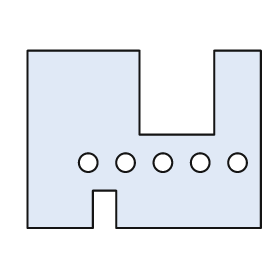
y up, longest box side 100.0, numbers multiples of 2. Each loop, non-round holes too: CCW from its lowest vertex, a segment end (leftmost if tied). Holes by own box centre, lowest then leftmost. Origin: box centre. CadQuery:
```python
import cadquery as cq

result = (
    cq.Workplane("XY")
    .moveTo(-50.0, -38.0)
    .lineTo(-22.0, -38.0)
    .lineTo(-22.0, -22.0)
    .lineTo(-12.0, -22.0)
    .lineTo(-12.0, -38.0)
    .lineTo(50.0, -38.0)
    .lineTo(50.0, 38.0)
    .lineTo(30.0, 38.0)
    .lineTo(30.0, 2.0)
    .lineTo(-2.0, 2.0)
    .lineTo(-2.0, 38.0)
    .lineTo(-50.0, 38.0)
    .close()
    .moveTo(-24.0, -10.0)
    .circle(4.0)
    .moveTo(-8.0, -10.0)
    .circle(4.0)
    .moveTo(8.0, -10.0)
    .circle(4.0)
    .moveTo(24.0, -10.0)
    .circle(4.0)
    .moveTo(40.0, -10.0)
    .circle(4.0)
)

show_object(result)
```